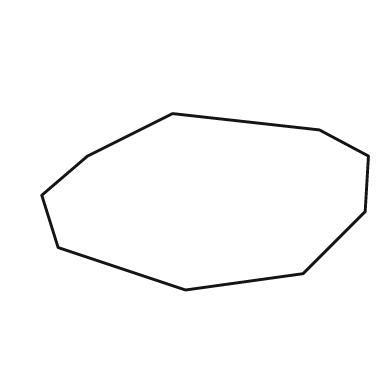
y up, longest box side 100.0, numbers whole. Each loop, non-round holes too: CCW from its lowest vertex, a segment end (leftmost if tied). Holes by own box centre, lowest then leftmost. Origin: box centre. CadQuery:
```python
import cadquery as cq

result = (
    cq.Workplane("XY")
    .moveTo(-6.0, -27.0)
    .lineTo(30.0, -22.0)
    .lineTo(49.0, -3.0)
    .lineTo(50.0, 14.0)
    .lineTo(35.0, 22.0)
    .lineTo(-10.0, 27.0)
    .lineTo(-36.0, 14.0)
    .lineTo(-50.0, 2.0)
    .lineTo(-45.0, -14.0)
    .close()
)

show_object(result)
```